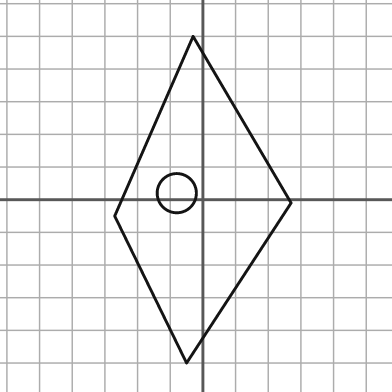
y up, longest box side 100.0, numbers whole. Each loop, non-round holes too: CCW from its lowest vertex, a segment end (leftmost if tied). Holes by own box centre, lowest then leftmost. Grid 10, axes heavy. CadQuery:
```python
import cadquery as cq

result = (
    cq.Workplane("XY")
    .moveTo(-5.0, -50.0)
    .lineTo(27.0, -1.0)
    .lineTo(-3.0, 50.0)
    .lineTo(-27.0, -5.0)
    .close()
    .moveTo(-8.0, 2.0)
    .circle(6.0)
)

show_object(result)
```